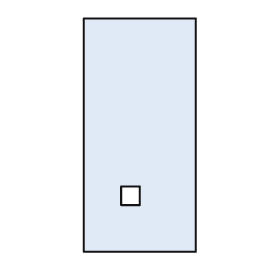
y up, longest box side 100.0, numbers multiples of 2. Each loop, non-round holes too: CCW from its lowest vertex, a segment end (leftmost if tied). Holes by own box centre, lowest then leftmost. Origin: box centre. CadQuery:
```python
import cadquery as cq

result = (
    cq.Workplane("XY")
    .moveTo(-24.0, -50.0)
    .lineTo(24.0, -50.0)
    .lineTo(24.0, 50.0)
    .lineTo(-24.0, 50.0)
    .close()
    .moveTo(-8.0, -30.0)
    .lineTo(0.0, -30.0)
    .lineTo(0.0, -22.0)
    .lineTo(-8.0, -22.0)
    .close()
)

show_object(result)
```